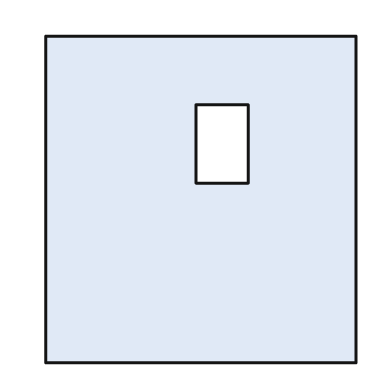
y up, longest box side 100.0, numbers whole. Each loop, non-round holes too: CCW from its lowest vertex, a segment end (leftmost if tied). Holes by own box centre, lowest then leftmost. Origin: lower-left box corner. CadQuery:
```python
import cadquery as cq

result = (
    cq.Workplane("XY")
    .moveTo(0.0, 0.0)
    .lineTo(95.0, 0.0)
    .lineTo(95.0, 100.0)
    .lineTo(0.0, 100.0)
    .close()
    .moveTo(46.0, 55.0)
    .lineTo(62.0, 55.0)
    .lineTo(62.0, 79.0)
    .lineTo(46.0, 79.0)
    .close()
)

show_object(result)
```